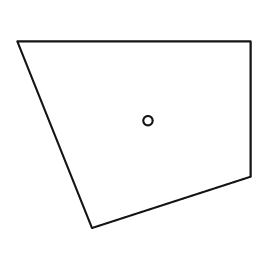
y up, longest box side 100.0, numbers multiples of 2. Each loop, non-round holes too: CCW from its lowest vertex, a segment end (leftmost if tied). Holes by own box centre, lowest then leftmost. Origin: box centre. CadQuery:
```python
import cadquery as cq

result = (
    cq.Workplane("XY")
    .moveTo(-18.0, -40.0)
    .lineTo(50.0, -18.0)
    .lineTo(50.0, 40.0)
    .lineTo(-50.0, 40.0)
    .close()
    .moveTo(6.0, 6.0)
    .circle(2.0)
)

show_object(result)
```